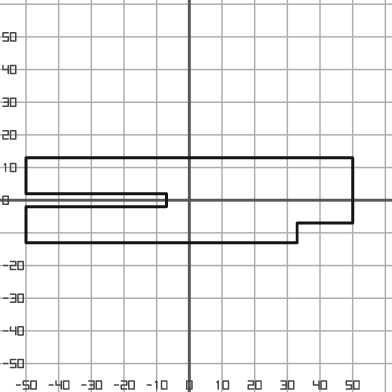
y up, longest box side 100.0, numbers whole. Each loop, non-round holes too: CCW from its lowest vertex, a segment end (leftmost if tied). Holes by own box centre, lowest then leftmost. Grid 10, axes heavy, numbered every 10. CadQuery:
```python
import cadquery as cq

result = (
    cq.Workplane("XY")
    .moveTo(-50.0, -13.0)
    .lineTo(33.0, -13.0)
    .lineTo(33.0, -7.0)
    .lineTo(50.0, -7.0)
    .lineTo(50.0, 13.0)
    .lineTo(-50.0, 13.0)
    .lineTo(-50.0, 2.0)
    .lineTo(-7.0, 2.0)
    .lineTo(-7.0, -2.0)
    .lineTo(-50.0, -2.0)
    .close()
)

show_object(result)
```